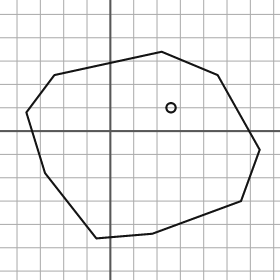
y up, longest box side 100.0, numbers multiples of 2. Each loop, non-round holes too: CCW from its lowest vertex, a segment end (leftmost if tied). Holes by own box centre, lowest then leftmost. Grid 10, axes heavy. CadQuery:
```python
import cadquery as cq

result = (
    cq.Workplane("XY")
    .moveTo(-6.0, -46.0)
    .lineTo(18.0, -44.0)
    .lineTo(56.0, -30.0)
    .lineTo(64.0, -8.0)
    .lineTo(46.0, 24.0)
    .lineTo(22.0, 34.0)
    .lineTo(-24.0, 24.0)
    .lineTo(-36.0, 8.0)
    .lineTo(-28.0, -18.0)
    .close()
    .moveTo(26.0, 10.0)
    .circle(2.0)
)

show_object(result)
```